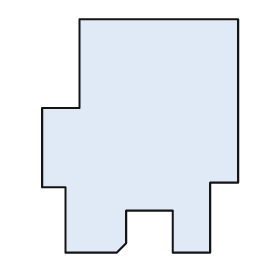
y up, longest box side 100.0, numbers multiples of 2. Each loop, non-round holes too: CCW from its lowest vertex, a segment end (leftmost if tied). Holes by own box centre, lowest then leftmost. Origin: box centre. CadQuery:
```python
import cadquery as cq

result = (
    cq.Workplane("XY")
    .moveTo(-32.0, -50.0)
    .lineTo(-10.0, -50.0)
    .lineTo(-6.0, -46.0)
    .lineTo(-6.0, -32.0)
    .lineTo(14.0, -32.0)
    .lineTo(14.0, -50.0)
    .lineTo(30.0, -50.0)
    .lineTo(30.0, -20.0)
    .lineTo(42.0, -20.0)
    .lineTo(42.0, 50.0)
    .lineTo(-26.0, 50.0)
    .lineTo(-26.0, 12.0)
    .lineTo(-42.0, 12.0)
    .lineTo(-42.0, -22.0)
    .lineTo(-32.0, -22.0)
    .close()
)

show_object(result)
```